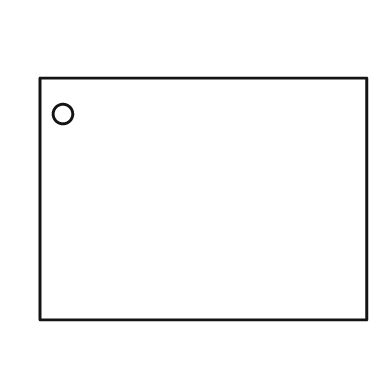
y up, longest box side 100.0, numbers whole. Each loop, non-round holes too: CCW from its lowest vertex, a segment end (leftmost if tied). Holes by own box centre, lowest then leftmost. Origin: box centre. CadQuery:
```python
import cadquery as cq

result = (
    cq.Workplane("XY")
    .moveTo(-50.0, -37.0)
    .lineTo(50.0, -37.0)
    .lineTo(50.0, 37.0)
    .lineTo(-50.0, 37.0)
    .close()
    .moveTo(-43.0, 26.0)
    .circle(3.0)
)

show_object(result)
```